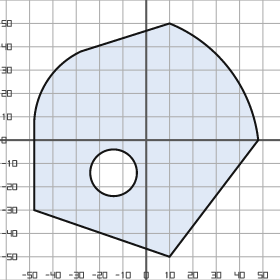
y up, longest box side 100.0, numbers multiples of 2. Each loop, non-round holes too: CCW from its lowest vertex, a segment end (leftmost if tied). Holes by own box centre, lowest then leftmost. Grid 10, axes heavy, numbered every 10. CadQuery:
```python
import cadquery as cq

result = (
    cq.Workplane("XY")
    .moveTo(10.0, -50.0)
    .lineTo(48.0, 0.0)
    .threePointArc((36.0, 30.0), (10.0, 50.0))
    .lineTo(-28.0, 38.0)
    .threePointArc((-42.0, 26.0), (-48.0, 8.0))
    .lineTo(-48.0, -30.0)
    .close()
    .moveTo(-14.0, -14.0)
    .circle(10.0)
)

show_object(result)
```